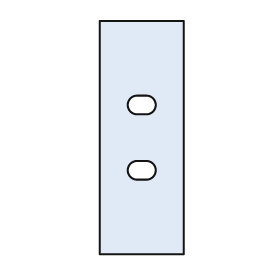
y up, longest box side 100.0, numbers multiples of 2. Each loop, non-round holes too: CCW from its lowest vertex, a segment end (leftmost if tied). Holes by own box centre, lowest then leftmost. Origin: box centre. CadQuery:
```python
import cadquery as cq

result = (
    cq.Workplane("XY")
    .moveTo(-18.0, -50.0)
    .lineTo(18.0, -50.0)
    .lineTo(18.0, 50.0)
    .lineTo(-18.0, 50.0)
    .close()
    .moveTo(-2.0, -18.0)
    .lineTo(2.0, -18.0)
    .threePointArc((6.0, -14.0), (2.0, -10.0))
    .lineTo(-2.0, -10.0)
    .threePointArc((-6.0, -14.0), (-2.0, -18.0))
    .close()
    .moveTo(-2.0, 10.0)
    .lineTo(2.0, 10.0)
    .threePointArc((6.0, 14.0), (2.0, 18.0))
    .lineTo(-2.0, 18.0)
    .threePointArc((-6.0, 14.0), (-2.0, 10.0))
    .close()
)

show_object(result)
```